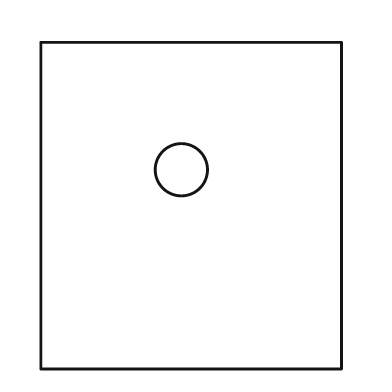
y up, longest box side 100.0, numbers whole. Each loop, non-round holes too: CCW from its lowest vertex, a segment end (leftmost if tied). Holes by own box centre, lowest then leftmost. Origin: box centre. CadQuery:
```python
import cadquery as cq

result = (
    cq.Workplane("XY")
    .moveTo(-46.0, -50.0)
    .lineTo(46.0, -50.0)
    .lineTo(46.0, 50.0)
    .lineTo(-46.0, 50.0)
    .close()
    .moveTo(-3.0, 11.0)
    .circle(8.0)
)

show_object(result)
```